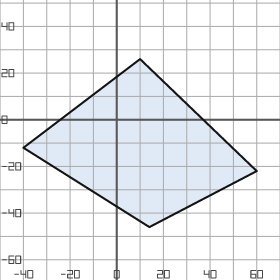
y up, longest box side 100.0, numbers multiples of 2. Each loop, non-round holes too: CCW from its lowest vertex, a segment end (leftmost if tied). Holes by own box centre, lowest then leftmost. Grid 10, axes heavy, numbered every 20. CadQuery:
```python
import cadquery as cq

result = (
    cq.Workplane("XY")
    .moveTo(14.0, -46.0)
    .lineTo(60.0, -22.0)
    .lineTo(10.0, 26.0)
    .lineTo(-40.0, -12.0)
    .close()
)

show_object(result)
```